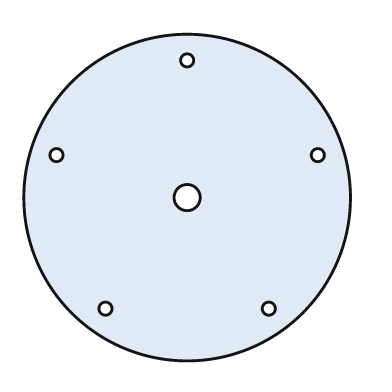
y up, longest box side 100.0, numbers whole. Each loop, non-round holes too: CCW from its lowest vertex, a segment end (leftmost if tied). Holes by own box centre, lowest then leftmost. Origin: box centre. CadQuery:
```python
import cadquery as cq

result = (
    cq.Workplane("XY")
    .moveTo(0.0, 0.0)
    .circle(50.0)
    .moveTo(-25.0, -34.0)
    .circle(2.0)
    .moveTo(25.0, -34.0)
    .circle(2.0)
    .moveTo(0.0, 0.0)
    .circle(4.0)
    .moveTo(-40.0, 13.0)
    .circle(2.0)
    .moveTo(40.0, 13.0)
    .circle(2.0)
    .moveTo(0.0, 42.0)
    .circle(2.0)
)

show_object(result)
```